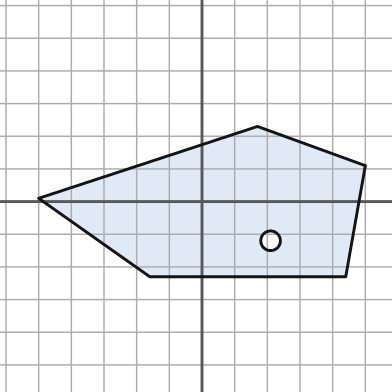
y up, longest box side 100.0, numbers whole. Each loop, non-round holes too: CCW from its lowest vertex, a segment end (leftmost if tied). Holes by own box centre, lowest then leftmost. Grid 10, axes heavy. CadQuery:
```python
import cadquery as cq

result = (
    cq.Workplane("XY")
    .moveTo(-16.0, -23.0)
    .lineTo(44.0, -23.0)
    .lineTo(50.0, 11.0)
    .lineTo(17.0, 23.0)
    .lineTo(-50.0, 1.0)
    .close()
    .moveTo(21.0, -12.0)
    .circle(3.0)
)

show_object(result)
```